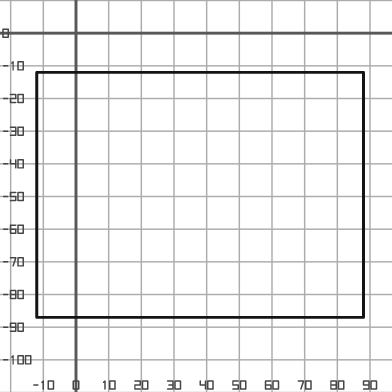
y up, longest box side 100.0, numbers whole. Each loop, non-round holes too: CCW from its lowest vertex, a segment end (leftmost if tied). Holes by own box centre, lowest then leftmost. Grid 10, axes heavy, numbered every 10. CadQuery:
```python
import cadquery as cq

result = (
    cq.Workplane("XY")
    .moveTo(-12.0, -87.0)
    .lineTo(88.0, -87.0)
    .lineTo(88.0, -12.0)
    .lineTo(-12.0, -12.0)
    .close()
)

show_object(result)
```